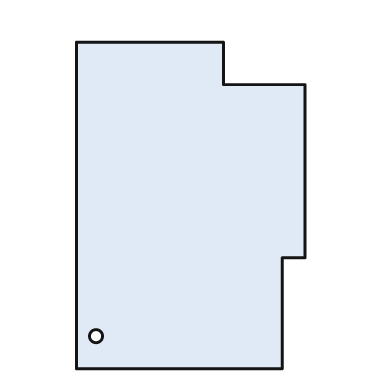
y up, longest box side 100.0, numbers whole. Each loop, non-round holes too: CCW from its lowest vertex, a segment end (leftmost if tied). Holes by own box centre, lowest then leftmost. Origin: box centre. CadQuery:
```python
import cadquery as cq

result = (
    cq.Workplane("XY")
    .moveTo(-35.0, -50.0)
    .lineTo(28.0, -50.0)
    .lineTo(28.0, -16.0)
    .lineTo(35.0, -16.0)
    .lineTo(35.0, 37.0)
    .lineTo(10.0, 37.0)
    .lineTo(10.0, 50.0)
    .lineTo(-35.0, 50.0)
    .close()
    .moveTo(-29.0, -40.0)
    .circle(2.0)
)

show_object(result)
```